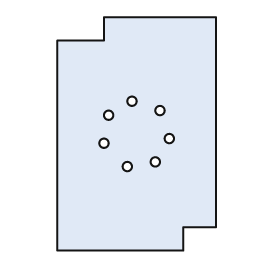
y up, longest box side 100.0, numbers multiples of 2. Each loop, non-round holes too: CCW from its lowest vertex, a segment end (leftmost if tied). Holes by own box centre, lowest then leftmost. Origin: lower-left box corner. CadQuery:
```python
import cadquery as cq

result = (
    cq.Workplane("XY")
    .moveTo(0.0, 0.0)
    .lineTo(54.0, 0.0)
    .lineTo(54.0, 10.0)
    .lineTo(68.0, 10.0)
    .lineTo(68.0, 100.0)
    .lineTo(20.0, 100.0)
    .lineTo(20.0, 90.0)
    .lineTo(0.0, 90.0)
    .close()
    .moveTo(30.0, 36.0)
    .circle(2.0)
    .moveTo(42.0, 38.0)
    .circle(2.0)
    .moveTo(20.0, 46.0)
    .circle(2.0)
    .moveTo(48.0, 48.0)
    .circle(2.0)
    .moveTo(22.0, 58.0)
    .circle(2.0)
    .moveTo(44.0, 60.0)
    .circle(2.0)
    .moveTo(32.0, 64.0)
    .circle(2.0)
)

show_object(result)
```